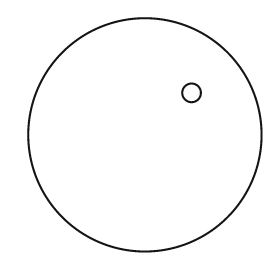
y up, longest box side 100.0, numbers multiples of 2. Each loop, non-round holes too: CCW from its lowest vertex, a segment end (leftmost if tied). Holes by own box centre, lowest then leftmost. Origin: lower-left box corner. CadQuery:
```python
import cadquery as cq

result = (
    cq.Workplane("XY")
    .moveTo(50.0, 50.0)
    .circle(50.0)
    .moveTo(70.0, 68.0)
    .circle(4.0)
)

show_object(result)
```